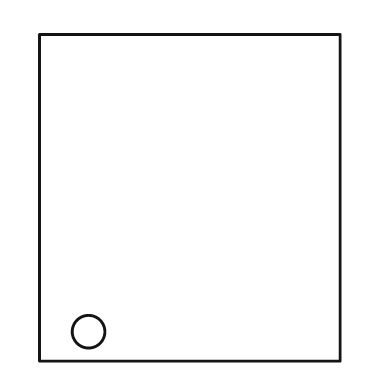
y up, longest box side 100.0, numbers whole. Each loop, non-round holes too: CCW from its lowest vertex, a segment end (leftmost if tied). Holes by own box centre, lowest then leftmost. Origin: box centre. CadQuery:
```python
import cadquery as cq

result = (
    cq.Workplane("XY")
    .moveTo(-46.0, -50.0)
    .lineTo(46.0, -50.0)
    .lineTo(46.0, 50.0)
    .lineTo(-46.0, 50.0)
    .close()
    .moveTo(-31.0, -41.0)
    .circle(5.0)
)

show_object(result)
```